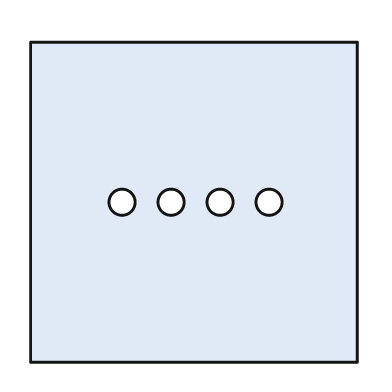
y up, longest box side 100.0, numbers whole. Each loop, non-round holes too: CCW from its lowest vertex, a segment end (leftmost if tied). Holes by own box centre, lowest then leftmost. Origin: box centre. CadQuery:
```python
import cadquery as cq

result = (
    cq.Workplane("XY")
    .moveTo(-50.0, -49.0)
    .lineTo(50.0, -49.0)
    .lineTo(50.0, 49.0)
    .lineTo(-50.0, 49.0)
    .close()
    .moveTo(-22.0, 0.0)
    .circle(4.0)
    .moveTo(-7.0, 0.0)
    .circle(4.0)
    .moveTo(8.0, 0.0)
    .circle(4.0)
    .moveTo(23.0, 0.0)
    .circle(4.0)
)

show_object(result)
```